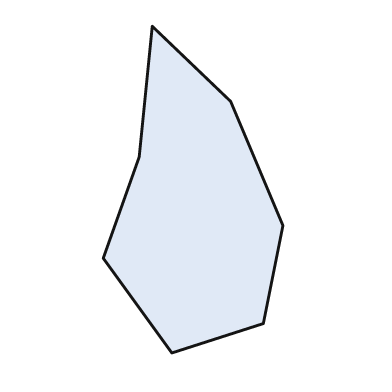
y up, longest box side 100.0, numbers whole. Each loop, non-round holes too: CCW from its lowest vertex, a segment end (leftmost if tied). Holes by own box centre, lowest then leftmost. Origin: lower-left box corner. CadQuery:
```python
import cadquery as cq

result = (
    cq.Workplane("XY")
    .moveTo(21.0, 0.0)
    .lineTo(49.0, 9.0)
    .lineTo(55.0, 39.0)
    .lineTo(39.0, 77.0)
    .lineTo(15.0, 100.0)
    .lineTo(11.0, 60.0)
    .lineTo(0.0, 29.0)
    .close()
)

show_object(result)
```